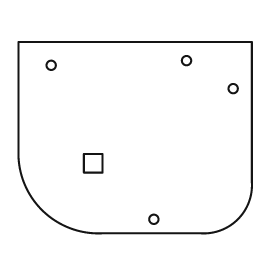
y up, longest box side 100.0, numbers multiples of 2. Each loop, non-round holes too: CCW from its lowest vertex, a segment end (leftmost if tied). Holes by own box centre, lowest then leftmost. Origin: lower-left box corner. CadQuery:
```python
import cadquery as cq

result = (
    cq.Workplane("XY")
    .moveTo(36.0, 0.0)
    .lineTo(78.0, 0.0)
    .threePointArc((94.0, 6.0), (100.0, 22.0))
    .lineTo(100.0, 82.0)
    .lineTo(0.0, 82.0)
    .lineTo(0.0, 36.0)
    .threePointArc((10.0, 10.0), (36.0, 0.0))
    .close()
    .moveTo(58.0, 6.0)
    .circle(2.0)
    .moveTo(28.0, 26.0)
    .lineTo(36.0, 26.0)
    .lineTo(36.0, 34.0)
    .lineTo(28.0, 34.0)
    .close()
    .moveTo(92.0, 62.0)
    .circle(2.0)
    .moveTo(14.0, 72.0)
    .circle(2.0)
    .moveTo(72.0, 74.0)
    .circle(2.0)
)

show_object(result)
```